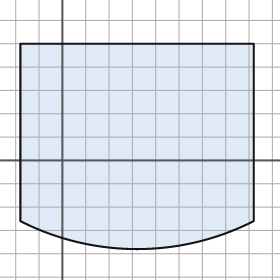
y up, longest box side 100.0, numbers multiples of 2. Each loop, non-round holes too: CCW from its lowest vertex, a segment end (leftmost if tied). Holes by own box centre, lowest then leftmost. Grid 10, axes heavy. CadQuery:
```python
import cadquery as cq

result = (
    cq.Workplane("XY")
    .moveTo(-18.0, -26.0)
    .threePointArc((32.0, -38.0), (82.0, -26.0))
    .lineTo(82.0, 50.0)
    .lineTo(-18.0, 50.0)
    .close()
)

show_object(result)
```